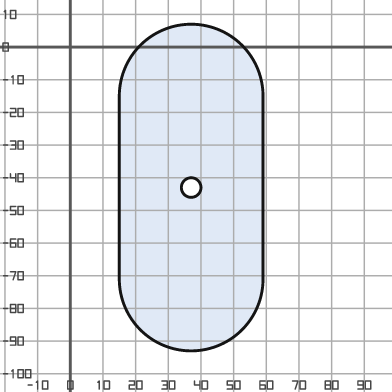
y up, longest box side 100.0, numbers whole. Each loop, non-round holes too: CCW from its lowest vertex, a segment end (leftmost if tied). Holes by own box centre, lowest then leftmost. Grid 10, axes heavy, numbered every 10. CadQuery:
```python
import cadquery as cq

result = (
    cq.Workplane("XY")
    .moveTo(15.0, -71.0)
    .threePointArc((37.0, -93.0), (59.0, -71.0))
    .lineTo(59.0, -15.0)
    .threePointArc((37.0, 7.0), (15.0, -15.0))
    .close()
    .moveTo(37.0, -43.0)
    .circle(3.0)
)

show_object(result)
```